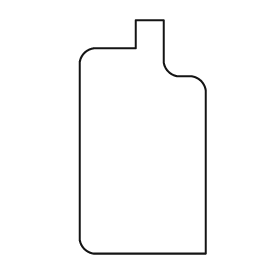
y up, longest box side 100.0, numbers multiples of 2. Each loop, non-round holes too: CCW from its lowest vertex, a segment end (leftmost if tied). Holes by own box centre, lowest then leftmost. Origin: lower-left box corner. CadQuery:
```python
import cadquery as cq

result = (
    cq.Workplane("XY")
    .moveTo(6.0, 0.0)
    .lineTo(54.0, 0.0)
    .lineTo(54.0, 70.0)
    .threePointArc((52.0, 74.0), (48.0, 76.0))
    .lineTo(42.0, 76.0)
    .threePointArc((38.0, 78.0), (36.0, 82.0))
    .lineTo(36.0, 100.0)
    .lineTo(24.0, 100.0)
    .lineTo(24.0, 88.0)
    .lineTo(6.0, 88.0)
    .threePointArc((2.0, 86.0), (0.0, 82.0))
    .lineTo(0.0, 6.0)
    .threePointArc((2.0, 2.0), (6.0, 0.0))
    .close()
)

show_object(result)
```